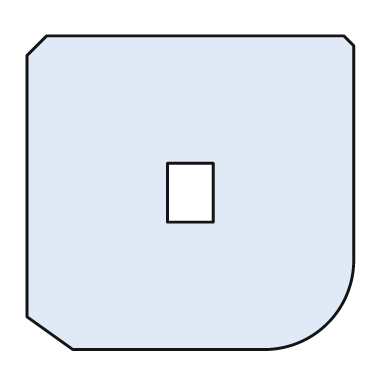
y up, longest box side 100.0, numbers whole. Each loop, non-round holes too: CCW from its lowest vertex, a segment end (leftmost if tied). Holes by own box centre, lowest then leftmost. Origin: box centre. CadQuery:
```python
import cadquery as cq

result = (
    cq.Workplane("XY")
    .moveTo(-36.0, -48.0)
    .lineTo(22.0, -48.0)
    .threePointArc((42.0, -40.0), (50.0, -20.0))
    .lineTo(50.0, 45.0)
    .lineTo(47.0, 48.0)
    .lineTo(-44.0, 48.0)
    .lineTo(-50.0, 42.0)
    .lineTo(-50.0, -38.0)
    .close()
    .moveTo(-7.0, -9.0)
    .lineTo(7.0, -9.0)
    .lineTo(7.0, 9.0)
    .lineTo(-7.0, 9.0)
    .close()
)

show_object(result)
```